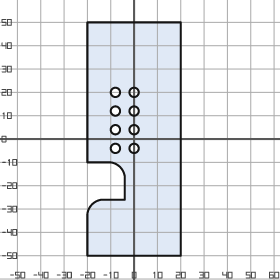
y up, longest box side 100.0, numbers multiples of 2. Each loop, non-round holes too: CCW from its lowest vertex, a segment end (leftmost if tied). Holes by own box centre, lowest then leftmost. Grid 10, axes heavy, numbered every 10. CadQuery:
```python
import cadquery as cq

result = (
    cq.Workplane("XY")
    .moveTo(-20.0, -50.0)
    .lineTo(20.0, -50.0)
    .lineTo(20.0, 50.0)
    .lineTo(-20.0, 50.0)
    .lineTo(-20.0, -10.0)
    .lineTo(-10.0, -10.0)
    .threePointArc((-6.0, -12.0), (-4.0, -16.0))
    .lineTo(-4.0, -26.0)
    .lineTo(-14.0, -26.0)
    .threePointArc((-18.0, -28.0), (-20.0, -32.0))
    .close()
    .moveTo(-8.0, -4.0)
    .circle(2.0)
    .moveTo(0.0, -4.0)
    .circle(2.0)
    .moveTo(-8.0, 4.0)
    .circle(2.0)
    .moveTo(0.0, 4.0)
    .circle(2.0)
    .moveTo(-8.0, 12.0)
    .circle(2.0)
    .moveTo(0.0, 12.0)
    .circle(2.0)
    .moveTo(-8.0, 20.0)
    .circle(2.0)
    .moveTo(0.0, 20.0)
    .circle(2.0)
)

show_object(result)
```